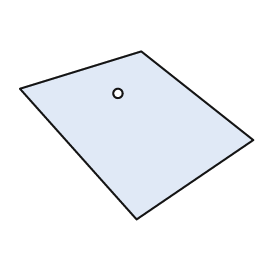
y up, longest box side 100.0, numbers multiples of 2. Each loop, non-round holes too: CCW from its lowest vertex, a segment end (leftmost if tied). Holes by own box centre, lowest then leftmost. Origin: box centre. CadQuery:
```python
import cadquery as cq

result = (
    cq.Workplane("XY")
    .moveTo(0.0, -36.0)
    .lineTo(50.0, -2.0)
    .lineTo(2.0, 36.0)
    .lineTo(-50.0, 20.0)
    .close()
    .moveTo(-8.0, 18.0)
    .circle(2.0)
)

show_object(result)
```